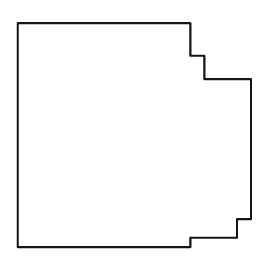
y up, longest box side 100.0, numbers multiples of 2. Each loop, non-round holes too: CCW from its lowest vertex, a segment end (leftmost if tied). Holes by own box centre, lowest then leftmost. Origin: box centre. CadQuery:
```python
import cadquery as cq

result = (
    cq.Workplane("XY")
    .moveTo(-50.0, -48.0)
    .lineTo(24.0, -48.0)
    .lineTo(24.0, -44.0)
    .lineTo(44.0, -44.0)
    .lineTo(44.0, -36.0)
    .lineTo(50.0, -36.0)
    .lineTo(50.0, 24.0)
    .lineTo(30.0, 24.0)
    .lineTo(30.0, 34.0)
    .lineTo(24.0, 34.0)
    .lineTo(24.0, 48.0)
    .lineTo(-50.0, 48.0)
    .close()
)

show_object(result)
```